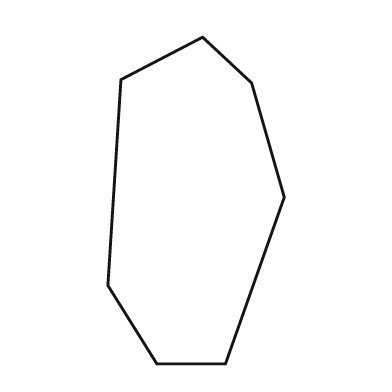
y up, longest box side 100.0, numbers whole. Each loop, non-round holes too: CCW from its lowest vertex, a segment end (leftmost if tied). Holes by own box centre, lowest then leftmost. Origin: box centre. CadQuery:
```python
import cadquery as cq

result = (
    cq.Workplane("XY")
    .moveTo(-12.0, -50.0)
    .lineTo(9.0, -50.0)
    .lineTo(27.0, 1.0)
    .lineTo(17.0, 36.0)
    .lineTo(2.0, 50.0)
    .lineTo(-23.0, 37.0)
    .lineTo(-27.0, -26.0)
    .close()
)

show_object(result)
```